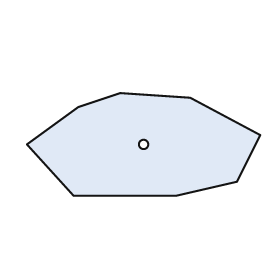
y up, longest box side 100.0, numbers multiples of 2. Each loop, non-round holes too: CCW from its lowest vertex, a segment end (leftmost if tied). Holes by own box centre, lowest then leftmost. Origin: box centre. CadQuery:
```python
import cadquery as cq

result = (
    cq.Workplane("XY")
    .moveTo(-30.0, -22.0)
    .lineTo(14.0, -22.0)
    .lineTo(40.0, -16.0)
    .lineTo(50.0, 4.0)
    .lineTo(20.0, 20.0)
    .lineTo(-10.0, 22.0)
    .lineTo(-28.0, 16.0)
    .lineTo(-50.0, 0.0)
    .close()
    .moveTo(0.0, 0.0)
    .circle(2.0)
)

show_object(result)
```